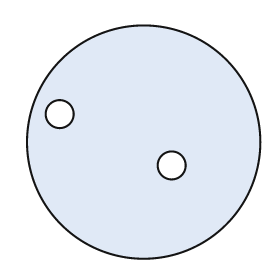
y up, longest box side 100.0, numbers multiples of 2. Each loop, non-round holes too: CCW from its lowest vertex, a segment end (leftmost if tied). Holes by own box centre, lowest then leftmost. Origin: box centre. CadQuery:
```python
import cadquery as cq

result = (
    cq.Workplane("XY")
    .moveTo(0.0, 0.0)
    .circle(50.0)
    .moveTo(12.0, -10.0)
    .circle(6.0)
    .moveTo(-36.0, 12.0)
    .circle(6.0)
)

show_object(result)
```